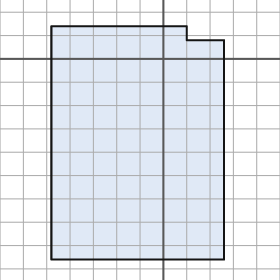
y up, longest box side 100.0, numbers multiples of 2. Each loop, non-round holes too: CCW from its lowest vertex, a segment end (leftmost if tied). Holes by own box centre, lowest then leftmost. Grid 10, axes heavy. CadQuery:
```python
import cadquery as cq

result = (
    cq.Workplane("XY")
    .moveTo(-48.0, -86.0)
    .lineTo(26.0, -86.0)
    .lineTo(26.0, 8.0)
    .lineTo(10.0, 8.0)
    .lineTo(10.0, 14.0)
    .lineTo(-48.0, 14.0)
    .close()
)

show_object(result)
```